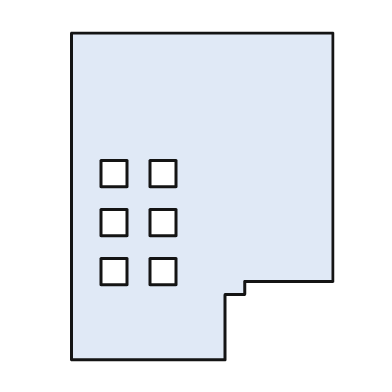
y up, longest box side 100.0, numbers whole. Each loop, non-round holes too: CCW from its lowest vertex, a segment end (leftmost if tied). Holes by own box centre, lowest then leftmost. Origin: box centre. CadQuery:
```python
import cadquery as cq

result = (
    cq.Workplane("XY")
    .moveTo(-40.0, -50.0)
    .lineTo(7.0, -50.0)
    .lineTo(7.0, -30.0)
    .lineTo(13.0, -30.0)
    .lineTo(13.0, -26.0)
    .lineTo(40.0, -26.0)
    .lineTo(40.0, 50.0)
    .lineTo(-40.0, 50.0)
    .close()
    .moveTo(-31.0, -27.0)
    .lineTo(-23.0, -27.0)
    .lineTo(-23.0, -19.0)
    .lineTo(-31.0, -19.0)
    .close()
    .moveTo(-16.0, -27.0)
    .lineTo(-8.0, -27.0)
    .lineTo(-8.0, -19.0)
    .lineTo(-16.0, -19.0)
    .close()
    .moveTo(-31.0, -12.0)
    .lineTo(-23.0, -12.0)
    .lineTo(-23.0, -4.0)
    .lineTo(-31.0, -4.0)
    .close()
    .moveTo(-16.0, -12.0)
    .lineTo(-8.0, -12.0)
    .lineTo(-8.0, -4.0)
    .lineTo(-16.0, -4.0)
    .close()
    .moveTo(-31.0, 3.0)
    .lineTo(-23.0, 3.0)
    .lineTo(-23.0, 11.0)
    .lineTo(-31.0, 11.0)
    .close()
    .moveTo(-16.0, 3.0)
    .lineTo(-8.0, 3.0)
    .lineTo(-8.0, 11.0)
    .lineTo(-16.0, 11.0)
    .close()
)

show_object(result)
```